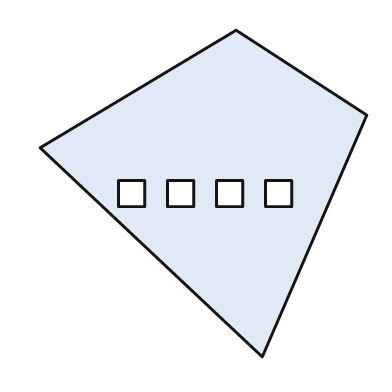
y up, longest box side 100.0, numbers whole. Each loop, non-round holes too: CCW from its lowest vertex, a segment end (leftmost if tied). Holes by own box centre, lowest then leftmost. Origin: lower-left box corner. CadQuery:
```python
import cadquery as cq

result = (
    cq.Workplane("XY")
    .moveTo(68.0, 0.0)
    .lineTo(100.0, 74.0)
    .lineTo(60.0, 100.0)
    .lineTo(0.0, 64.0)
    .close()
    .moveTo(24.0, 46.0)
    .lineTo(32.0, 46.0)
    .lineTo(32.0, 54.0)
    .lineTo(24.0, 54.0)
    .close()
    .moveTo(39.0, 46.0)
    .lineTo(47.0, 46.0)
    .lineTo(47.0, 54.0)
    .lineTo(39.0, 54.0)
    .close()
    .moveTo(54.0, 46.0)
    .lineTo(62.0, 46.0)
    .lineTo(62.0, 54.0)
    .lineTo(54.0, 54.0)
    .close()
    .moveTo(69.0, 46.0)
    .lineTo(77.0, 46.0)
    .lineTo(77.0, 54.0)
    .lineTo(69.0, 54.0)
    .close()
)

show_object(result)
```